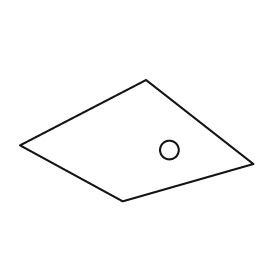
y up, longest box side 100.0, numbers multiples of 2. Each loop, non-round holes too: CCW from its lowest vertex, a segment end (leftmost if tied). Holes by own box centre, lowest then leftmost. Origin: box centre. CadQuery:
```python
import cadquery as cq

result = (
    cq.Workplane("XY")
    .moveTo(-6.0, -26.0)
    .lineTo(50.0, -10.0)
    .lineTo(4.0, 26.0)
    .lineTo(-50.0, -2.0)
    .close()
    .moveTo(14.0, -4.0)
    .circle(4.0)
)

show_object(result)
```